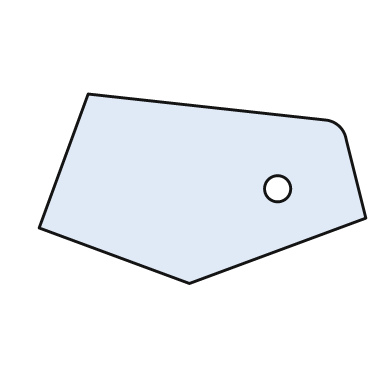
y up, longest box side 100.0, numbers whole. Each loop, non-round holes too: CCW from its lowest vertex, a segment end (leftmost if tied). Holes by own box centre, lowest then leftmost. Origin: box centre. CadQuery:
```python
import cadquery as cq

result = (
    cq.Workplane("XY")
    .moveTo(-4.0, -29.0)
    .lineTo(50.0, -9.0)
    .lineTo(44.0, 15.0)
    .threePointArc((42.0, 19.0), (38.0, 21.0))
    .lineTo(-35.0, 29.0)
    .lineTo(-50.0, -12.0)
    .close()
    .moveTo(23.0, 0.0)
    .circle(4.0)
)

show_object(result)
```